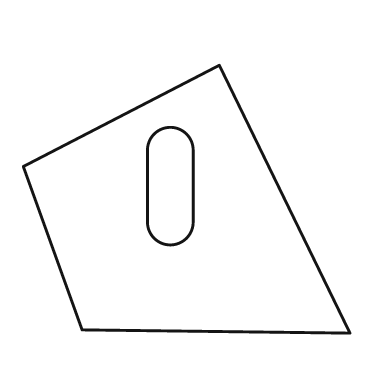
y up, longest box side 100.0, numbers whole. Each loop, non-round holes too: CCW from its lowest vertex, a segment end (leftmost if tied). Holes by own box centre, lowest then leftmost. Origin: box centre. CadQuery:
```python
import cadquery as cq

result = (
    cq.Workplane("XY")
    .moveTo(50.0, -41.0)
    .lineTo(10.0, 41.0)
    .lineTo(-50.0, 10.0)
    .lineTo(-32.0, -40.0)
    .close()
    .moveTo(-12.0, -7.0)
    .threePointArc((-5.0, -14.0), (2.0, -7.0))
    .lineTo(2.0, 15.0)
    .threePointArc((-5.0, 22.0), (-12.0, 15.0))
    .close()
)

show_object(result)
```